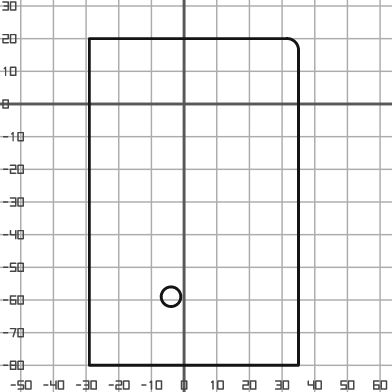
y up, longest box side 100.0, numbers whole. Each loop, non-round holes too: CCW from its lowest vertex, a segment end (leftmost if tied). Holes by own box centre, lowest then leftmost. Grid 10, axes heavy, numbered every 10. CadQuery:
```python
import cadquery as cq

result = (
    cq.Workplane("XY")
    .moveTo(-29.0, -80.0)
    .lineTo(35.0, -80.0)
    .lineTo(35.0, 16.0)
    .threePointArc((34.0, 19.0), (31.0, 20.0))
    .lineTo(-29.0, 20.0)
    .close()
    .moveTo(-4.0, -59.0)
    .circle(3.0)
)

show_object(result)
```